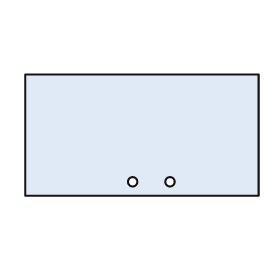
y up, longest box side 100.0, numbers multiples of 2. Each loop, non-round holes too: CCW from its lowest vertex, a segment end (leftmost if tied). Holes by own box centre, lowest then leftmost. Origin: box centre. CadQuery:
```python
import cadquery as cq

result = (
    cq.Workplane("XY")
    .moveTo(-50.0, -26.0)
    .lineTo(50.0, -26.0)
    .lineTo(50.0, 26.0)
    .lineTo(-50.0, 26.0)
    .close()
    .moveTo(-4.0, -20.0)
    .circle(2.0)
    .moveTo(12.0, -20.0)
    .circle(2.0)
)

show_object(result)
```